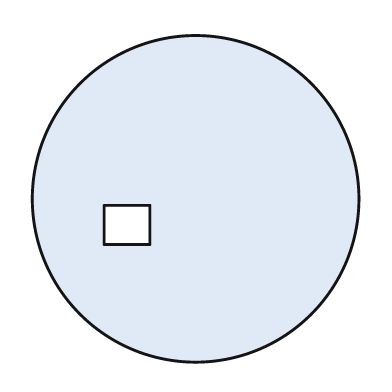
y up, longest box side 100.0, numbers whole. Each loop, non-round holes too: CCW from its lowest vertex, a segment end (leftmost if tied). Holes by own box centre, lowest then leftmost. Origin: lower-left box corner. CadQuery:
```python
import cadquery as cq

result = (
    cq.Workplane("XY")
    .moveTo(50.0, 50.0)
    .circle(50.0)
    .moveTo(22.0, 36.0)
    .lineTo(36.0, 36.0)
    .lineTo(36.0, 48.0)
    .lineTo(22.0, 48.0)
    .close()
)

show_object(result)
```